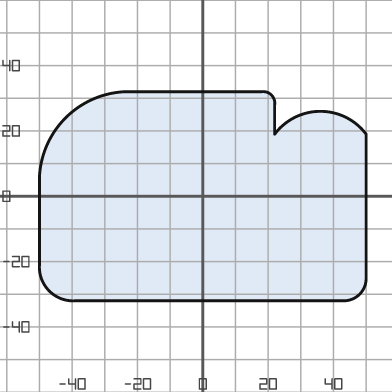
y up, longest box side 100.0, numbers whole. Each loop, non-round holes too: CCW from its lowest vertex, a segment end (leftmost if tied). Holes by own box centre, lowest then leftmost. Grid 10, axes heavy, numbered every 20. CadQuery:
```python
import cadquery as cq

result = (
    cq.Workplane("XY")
    .moveTo(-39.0, -32.0)
    .lineTo(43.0, -32.0)
    .threePointArc((48.0, -30.0), (50.0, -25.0))
    .lineTo(50.0, 19.0)
    .threePointArc((36.0, 26.0), (22.0, 19.0))
    .lineTo(22.0, 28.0)
    .threePointArc((21.0, 31.0), (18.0, 32.0))
    .lineTo(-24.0, 32.0)
    .threePointArc((-42.0, 24.0), (-50.0, 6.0))
    .lineTo(-50.0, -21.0)
    .threePointArc((-47.0, -29.0), (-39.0, -32.0))
    .close()
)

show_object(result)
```